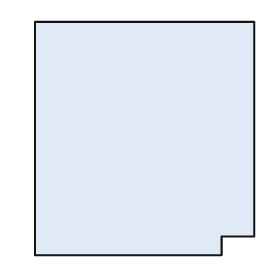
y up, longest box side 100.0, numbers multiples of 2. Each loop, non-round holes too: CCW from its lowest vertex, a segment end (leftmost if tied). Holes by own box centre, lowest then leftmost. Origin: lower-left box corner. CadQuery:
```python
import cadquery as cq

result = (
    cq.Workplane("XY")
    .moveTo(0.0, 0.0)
    .lineTo(80.0, 0.0)
    .lineTo(80.0, 8.0)
    .lineTo(94.0, 8.0)
    .lineTo(94.0, 100.0)
    .lineTo(0.0, 100.0)
    .close()
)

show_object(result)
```